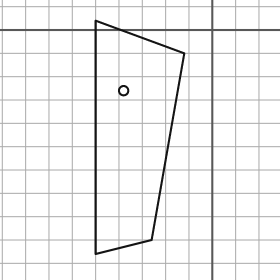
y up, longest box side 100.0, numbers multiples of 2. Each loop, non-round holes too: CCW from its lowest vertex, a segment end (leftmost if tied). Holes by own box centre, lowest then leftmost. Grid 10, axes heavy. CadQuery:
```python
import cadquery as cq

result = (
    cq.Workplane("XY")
    .moveTo(-50.0, -96.0)
    .lineTo(-26.0, -90.0)
    .lineTo(-12.0, -10.0)
    .lineTo(-50.0, 4.0)
    .close()
    .moveTo(-38.0, -26.0)
    .circle(2.0)
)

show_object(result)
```